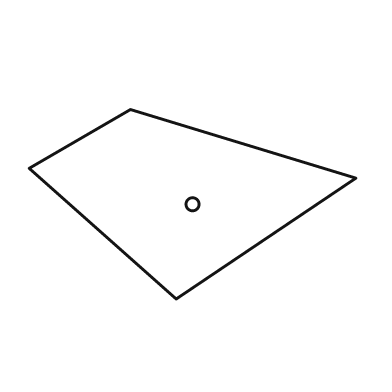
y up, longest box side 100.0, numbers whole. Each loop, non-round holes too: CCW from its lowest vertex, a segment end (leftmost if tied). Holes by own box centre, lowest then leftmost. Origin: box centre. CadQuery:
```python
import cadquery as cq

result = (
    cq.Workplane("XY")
    .moveTo(-5.0, -29.0)
    .lineTo(50.0, 8.0)
    .lineTo(-19.0, 29.0)
    .lineTo(-50.0, 11.0)
    .close()
    .moveTo(0.0, 0.0)
    .circle(2.0)
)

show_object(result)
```